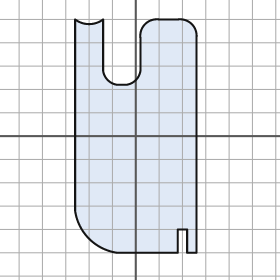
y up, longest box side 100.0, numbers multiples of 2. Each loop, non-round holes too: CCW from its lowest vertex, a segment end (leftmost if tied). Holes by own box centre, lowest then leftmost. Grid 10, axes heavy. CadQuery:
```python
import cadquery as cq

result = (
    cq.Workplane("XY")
    .moveTo(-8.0, -50.0)
    .lineTo(18.0, -50.0)
    .lineTo(18.0, -40.0)
    .lineTo(22.0, -40.0)
    .lineTo(22.0, -50.0)
    .lineTo(26.0, -50.0)
    .lineTo(26.0, 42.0)
    .threePointArc((24.0, 48.0), (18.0, 50.0))
    .lineTo(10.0, 50.0)
    .threePointArc((4.0, 48.0), (2.0, 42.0))
    .lineTo(2.0, 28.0)
    .threePointArc((0.0, 24.0), (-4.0, 22.0))
    .lineTo(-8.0, 22.0)
    .threePointArc((-12.0, 24.0), (-14.0, 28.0))
    .lineTo(-14.0, 50.0)
    .threePointArc((-20.0, 48.0), (-26.0, 50.0))
    .lineTo(-26.0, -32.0)
    .threePointArc((-20.0, -44.0), (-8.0, -50.0))
    .close()
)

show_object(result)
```